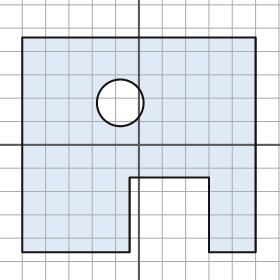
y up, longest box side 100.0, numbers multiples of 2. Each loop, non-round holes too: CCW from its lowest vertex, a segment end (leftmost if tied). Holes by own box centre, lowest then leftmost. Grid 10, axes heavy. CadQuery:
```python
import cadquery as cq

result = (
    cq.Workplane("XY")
    .moveTo(-50.0, -46.0)
    .lineTo(-4.0, -46.0)
    .lineTo(-4.0, -14.0)
    .lineTo(30.0, -14.0)
    .lineTo(30.0, -46.0)
    .lineTo(50.0, -46.0)
    .lineTo(50.0, 46.0)
    .lineTo(-50.0, 46.0)
    .close()
    .moveTo(-8.0, 18.0)
    .circle(10.0)
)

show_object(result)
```